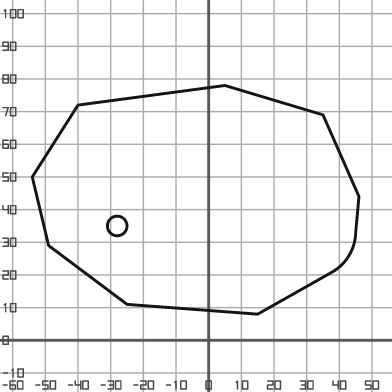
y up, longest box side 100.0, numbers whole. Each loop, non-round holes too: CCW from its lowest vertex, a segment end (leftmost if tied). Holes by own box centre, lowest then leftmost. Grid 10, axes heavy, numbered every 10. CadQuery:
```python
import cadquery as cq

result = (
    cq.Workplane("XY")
    .moveTo(15.0, 8.0)
    .lineTo(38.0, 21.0)
    .threePointArc((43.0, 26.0), (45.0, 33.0))
    .lineTo(46.0, 44.0)
    .lineTo(35.0, 69.0)
    .lineTo(5.0, 78.0)
    .lineTo(-40.0, 72.0)
    .lineTo(-54.0, 50.0)
    .lineTo(-49.0, 29.0)
    .lineTo(-25.0, 11.0)
    .close()
    .moveTo(-28.0, 35.0)
    .circle(3.0)
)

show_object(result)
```